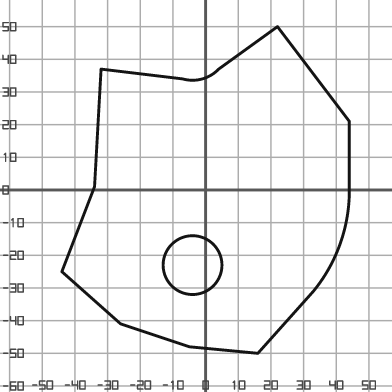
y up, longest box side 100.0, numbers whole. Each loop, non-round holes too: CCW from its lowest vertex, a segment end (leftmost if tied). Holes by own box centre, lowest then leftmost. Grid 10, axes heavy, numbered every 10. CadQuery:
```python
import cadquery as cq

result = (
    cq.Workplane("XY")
    .moveTo(16.0, -50.0)
    .lineTo(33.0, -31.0)
    .threePointArc((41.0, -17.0), (44.0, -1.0))
    .lineTo(44.0, 21.0)
    .lineTo(22.0, 50.0)
    .lineTo(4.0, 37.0)
    .threePointArc((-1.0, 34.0), (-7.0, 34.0))
    .lineTo(-32.0, 37.0)
    .lineTo(-34.0, 1.0)
    .lineTo(-44.0, -25.0)
    .lineTo(-26.0, -41.0)
    .lineTo(-5.0, -48.0)
    .close()
    .moveTo(-4.0, -23.0)
    .circle(9.0)
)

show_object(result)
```